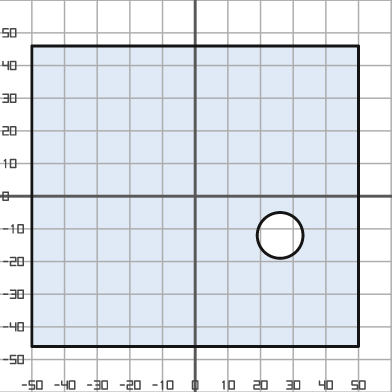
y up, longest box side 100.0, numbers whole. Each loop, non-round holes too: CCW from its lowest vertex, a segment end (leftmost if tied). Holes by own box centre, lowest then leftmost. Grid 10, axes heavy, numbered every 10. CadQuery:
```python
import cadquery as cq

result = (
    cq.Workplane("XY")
    .moveTo(-50.0, -46.0)
    .lineTo(50.0, -46.0)
    .lineTo(50.0, 46.0)
    .lineTo(-50.0, 46.0)
    .close()
    .moveTo(26.0, -12.0)
    .circle(7.0)
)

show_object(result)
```